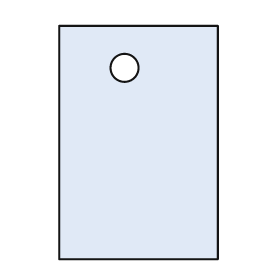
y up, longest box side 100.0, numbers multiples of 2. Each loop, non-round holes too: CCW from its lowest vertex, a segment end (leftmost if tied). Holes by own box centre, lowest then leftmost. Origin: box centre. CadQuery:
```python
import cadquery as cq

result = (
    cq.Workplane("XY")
    .moveTo(-34.0, -50.0)
    .lineTo(34.0, -50.0)
    .lineTo(34.0, 50.0)
    .lineTo(-34.0, 50.0)
    .close()
    .moveTo(-6.0, 32.0)
    .circle(6.0)
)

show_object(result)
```